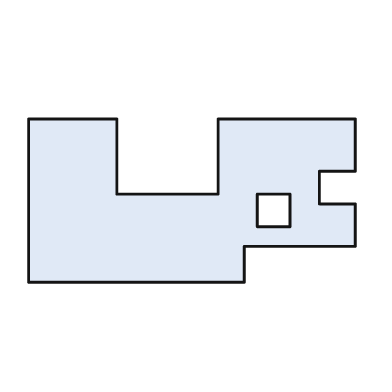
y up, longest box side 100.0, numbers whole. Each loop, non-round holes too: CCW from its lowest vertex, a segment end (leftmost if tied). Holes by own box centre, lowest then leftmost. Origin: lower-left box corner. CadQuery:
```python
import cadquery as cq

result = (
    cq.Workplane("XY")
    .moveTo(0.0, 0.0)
    .lineTo(66.0, 0.0)
    .lineTo(66.0, 11.0)
    .lineTo(100.0, 11.0)
    .lineTo(100.0, 24.0)
    .lineTo(89.0, 24.0)
    .lineTo(89.0, 34.0)
    .lineTo(100.0, 34.0)
    .lineTo(100.0, 50.0)
    .lineTo(58.0, 50.0)
    .lineTo(58.0, 27.0)
    .lineTo(27.0, 27.0)
    .lineTo(27.0, 50.0)
    .lineTo(0.0, 50.0)
    .close()
    .moveTo(70.0, 17.0)
    .lineTo(80.0, 17.0)
    .lineTo(80.0, 27.0)
    .lineTo(70.0, 27.0)
    .close()
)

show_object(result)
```